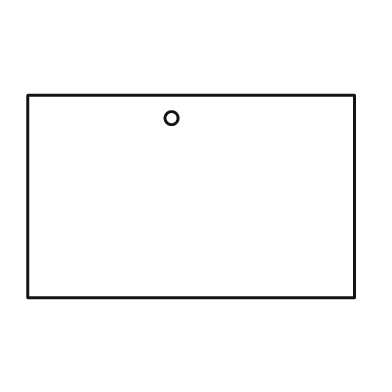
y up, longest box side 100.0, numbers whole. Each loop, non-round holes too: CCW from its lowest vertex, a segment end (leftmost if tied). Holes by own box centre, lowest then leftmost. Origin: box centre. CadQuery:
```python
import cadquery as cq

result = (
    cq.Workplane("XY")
    .moveTo(-50.0, -31.0)
    .lineTo(50.0, -31.0)
    .lineTo(50.0, 31.0)
    .lineTo(-50.0, 31.0)
    .close()
    .moveTo(-6.0, 24.0)
    .circle(2.0)
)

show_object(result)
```